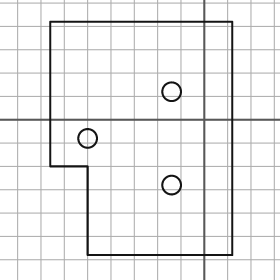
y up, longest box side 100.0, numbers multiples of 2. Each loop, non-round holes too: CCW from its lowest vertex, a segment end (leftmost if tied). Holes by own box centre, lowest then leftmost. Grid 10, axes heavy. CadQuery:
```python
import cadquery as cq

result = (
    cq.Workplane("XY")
    .moveTo(-50.0, -58.0)
    .lineTo(12.0, -58.0)
    .lineTo(12.0, 42.0)
    .lineTo(-66.0, 42.0)
    .lineTo(-66.0, -20.0)
    .lineTo(-50.0, -20.0)
    .close()
    .moveTo(-14.0, -28.0)
    .circle(4.0)
    .moveTo(-50.0, -8.0)
    .circle(4.0)
    .moveTo(-14.0, 12.0)
    .circle(4.0)
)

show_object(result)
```